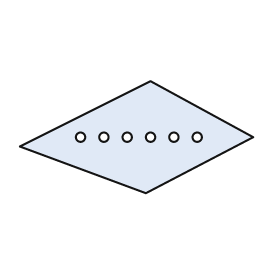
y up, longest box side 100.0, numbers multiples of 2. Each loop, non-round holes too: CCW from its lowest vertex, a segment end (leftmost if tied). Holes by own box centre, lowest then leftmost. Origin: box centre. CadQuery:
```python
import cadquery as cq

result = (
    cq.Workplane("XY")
    .moveTo(4.0, -24.0)
    .lineTo(50.0, 0.0)
    .lineTo(6.0, 24.0)
    .lineTo(-50.0, -4.0)
    .close()
    .moveTo(-24.0, 0.0)
    .circle(2.0)
    .moveTo(-14.0, 0.0)
    .circle(2.0)
    .moveTo(-4.0, 0.0)
    .circle(2.0)
    .moveTo(6.0, 0.0)
    .circle(2.0)
    .moveTo(16.0, 0.0)
    .circle(2.0)
    .moveTo(26.0, 0.0)
    .circle(2.0)
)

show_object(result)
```